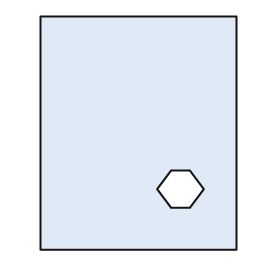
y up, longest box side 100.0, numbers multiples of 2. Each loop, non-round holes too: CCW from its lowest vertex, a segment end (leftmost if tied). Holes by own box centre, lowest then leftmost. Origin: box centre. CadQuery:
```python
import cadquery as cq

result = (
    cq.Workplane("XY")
    .moveTo(-42.0, -50.0)
    .lineTo(42.0, -50.0)
    .lineTo(42.0, 50.0)
    .lineTo(-42.0, 50.0)
    .close()
    .moveTo(14.0, -32.0)
    .lineTo(22.0, -32.0)
    .lineTo(28.0, -24.0)
    .lineTo(22.0, -16.0)
    .lineTo(14.0, -16.0)
    .lineTo(8.0, -24.0)
    .close()
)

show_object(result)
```